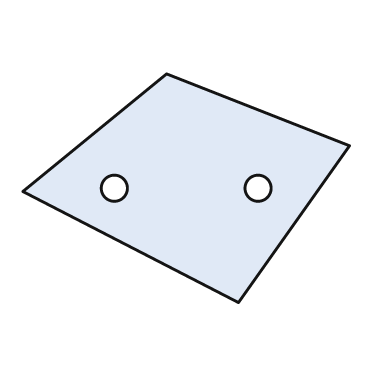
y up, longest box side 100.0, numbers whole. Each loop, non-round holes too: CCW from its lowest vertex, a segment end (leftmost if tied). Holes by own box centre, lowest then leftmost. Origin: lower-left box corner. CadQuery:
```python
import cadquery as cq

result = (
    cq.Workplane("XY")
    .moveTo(66.0, 0.0)
    .lineTo(100.0, 48.0)
    .lineTo(44.0, 70.0)
    .lineTo(0.0, 34.0)
    .close()
    .moveTo(28.0, 35.0)
    .circle(4.0)
    .moveTo(72.0, 35.0)
    .circle(4.0)
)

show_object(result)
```